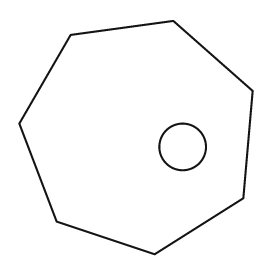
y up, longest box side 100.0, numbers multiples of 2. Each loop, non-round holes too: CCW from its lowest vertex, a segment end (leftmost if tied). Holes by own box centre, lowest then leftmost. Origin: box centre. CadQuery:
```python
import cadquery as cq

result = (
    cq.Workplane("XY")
    .moveTo(8.0, -50.0)
    .lineTo(46.0, -26.0)
    .lineTo(50.0, 20.0)
    .lineTo(16.0, 50.0)
    .lineTo(-28.0, 44.0)
    .lineTo(-50.0, 6.0)
    .lineTo(-34.0, -36.0)
    .close()
    .moveTo(20.0, -4.0)
    .circle(10.0)
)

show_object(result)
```